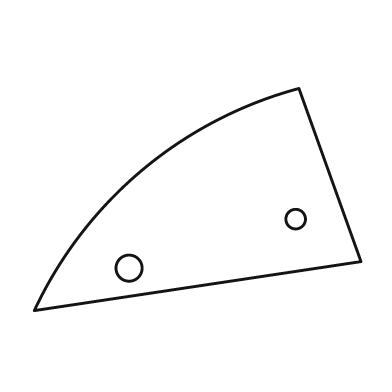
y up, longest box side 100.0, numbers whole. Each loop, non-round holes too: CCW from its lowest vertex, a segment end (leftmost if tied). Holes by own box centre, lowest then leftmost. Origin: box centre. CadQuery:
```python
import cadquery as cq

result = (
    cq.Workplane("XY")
    .moveTo(-50.0, -34.0)
    .lineTo(50.0, -19.0)
    .lineTo(31.0, 34.0)
    .threePointArc((-17.0, 9.0), (-50.0, -34.0))
    .close()
    .moveTo(-21.0, -21.0)
    .circle(4.0)
    .moveTo(30.0, -6.0)
    .circle(3.0)
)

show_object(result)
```